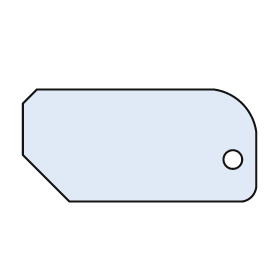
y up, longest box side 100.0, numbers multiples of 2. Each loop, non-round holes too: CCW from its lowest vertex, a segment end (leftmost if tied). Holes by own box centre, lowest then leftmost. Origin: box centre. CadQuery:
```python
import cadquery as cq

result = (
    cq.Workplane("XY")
    .moveTo(-30.0, -24.0)
    .lineTo(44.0, -24.0)
    .threePointArc((48.0, -22.0), (50.0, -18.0))
    .lineTo(50.0, 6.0)
    .threePointArc((44.0, 18.0), (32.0, 24.0))
    .lineTo(-44.0, 24.0)
    .lineTo(-50.0, 18.0)
    .lineTo(-50.0, -4.0)
    .close()
    .moveTo(40.0, -6.0)
    .circle(4.0)
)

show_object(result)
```